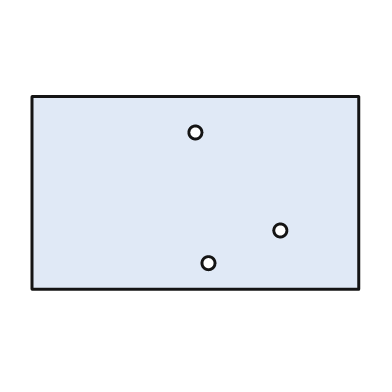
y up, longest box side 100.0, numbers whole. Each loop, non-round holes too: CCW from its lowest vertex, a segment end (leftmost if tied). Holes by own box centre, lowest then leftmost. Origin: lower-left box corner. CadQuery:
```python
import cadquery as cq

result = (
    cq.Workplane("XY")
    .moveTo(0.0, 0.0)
    .lineTo(100.0, 0.0)
    .lineTo(100.0, 59.0)
    .lineTo(0.0, 59.0)
    .close()
    .moveTo(54.0, 8.0)
    .circle(2.0)
    .moveTo(76.0, 18.0)
    .circle(2.0)
    .moveTo(50.0, 48.0)
    .circle(2.0)
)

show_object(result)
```